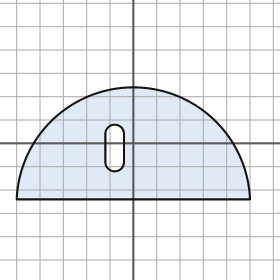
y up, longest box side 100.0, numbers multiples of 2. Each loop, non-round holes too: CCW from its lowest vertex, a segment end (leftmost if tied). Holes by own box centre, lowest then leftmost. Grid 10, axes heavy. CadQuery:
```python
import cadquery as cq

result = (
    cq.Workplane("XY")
    .moveTo(-50.0, -24.0)
    .lineTo(50.0, -24.0)
    .threePointArc((0.0, 24.0), (-50.0, -24.0))
    .close()
    .moveTo(-12.0, -8.0)
    .threePointArc((-8.0, -12.0), (-4.0, -8.0))
    .lineTo(-4.0, 4.0)
    .threePointArc((-8.0, 8.0), (-12.0, 4.0))
    .close()
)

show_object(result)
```